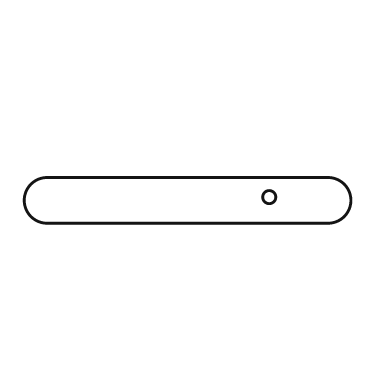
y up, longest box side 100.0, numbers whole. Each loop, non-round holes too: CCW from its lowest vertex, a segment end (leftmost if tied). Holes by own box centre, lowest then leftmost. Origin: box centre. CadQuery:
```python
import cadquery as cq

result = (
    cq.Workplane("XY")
    .moveTo(-43.0, -7.0)
    .lineTo(43.0, -7.0)
    .threePointArc((50.0, 0.0), (43.0, 7.0))
    .lineTo(-43.0, 7.0)
    .threePointArc((-50.0, 0.0), (-43.0, -7.0))
    .close()
    .moveTo(25.0, 1.0)
    .circle(2.0)
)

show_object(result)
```